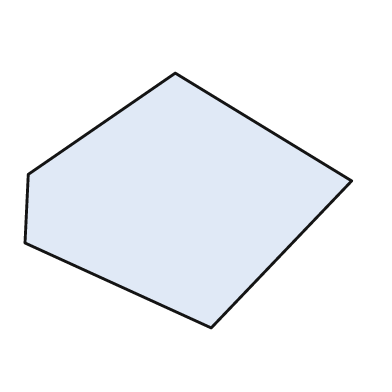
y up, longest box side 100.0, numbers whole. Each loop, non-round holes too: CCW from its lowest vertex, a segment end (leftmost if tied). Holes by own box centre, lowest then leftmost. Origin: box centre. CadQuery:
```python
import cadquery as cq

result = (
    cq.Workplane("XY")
    .moveTo(7.0, -39.0)
    .lineTo(50.0, 6.0)
    .lineTo(-4.0, 39.0)
    .lineTo(-49.0, 8.0)
    .lineTo(-50.0, -13.0)
    .close()
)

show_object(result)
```